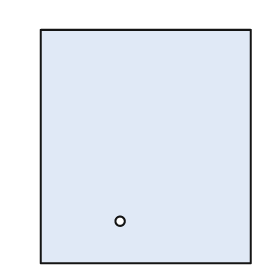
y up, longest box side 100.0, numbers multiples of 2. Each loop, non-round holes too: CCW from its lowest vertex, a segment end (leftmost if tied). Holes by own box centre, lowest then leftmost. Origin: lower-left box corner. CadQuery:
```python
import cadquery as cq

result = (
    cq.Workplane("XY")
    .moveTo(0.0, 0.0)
    .lineTo(90.0, 0.0)
    .lineTo(90.0, 100.0)
    .lineTo(0.0, 100.0)
    .close()
    .moveTo(34.0, 18.0)
    .circle(2.0)
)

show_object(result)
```